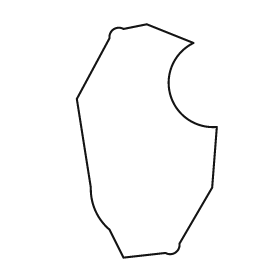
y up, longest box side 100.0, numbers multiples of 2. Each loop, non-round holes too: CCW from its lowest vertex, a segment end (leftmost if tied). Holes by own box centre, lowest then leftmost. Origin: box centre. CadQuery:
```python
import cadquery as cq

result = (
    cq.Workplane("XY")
    .moveTo(-10.0, -50.0)
    .lineTo(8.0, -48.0)
    .threePointArc((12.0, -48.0), (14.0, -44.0))
    .lineTo(28.0, -20.0)
    .lineTo(30.0, 6.0)
    .threePointArc((10.0, 20.0), (20.0, 42.0))
    .lineTo(0.0, 50.0)
    .lineTo(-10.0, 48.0)
    .threePointArc((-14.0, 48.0), (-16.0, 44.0))
    .lineTo(-30.0, 18.0)
    .lineTo(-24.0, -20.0)
    .threePointArc((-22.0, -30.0), (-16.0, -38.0))
    .close()
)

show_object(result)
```